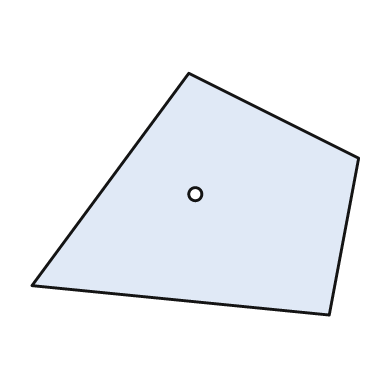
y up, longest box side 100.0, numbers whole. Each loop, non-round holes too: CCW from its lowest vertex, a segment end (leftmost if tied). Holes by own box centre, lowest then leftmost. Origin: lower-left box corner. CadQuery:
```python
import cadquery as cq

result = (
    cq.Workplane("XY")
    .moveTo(91.0, 0.0)
    .lineTo(100.0, 48.0)
    .lineTo(48.0, 74.0)
    .lineTo(0.0, 9.0)
    .close()
    .moveTo(50.0, 37.0)
    .circle(2.0)
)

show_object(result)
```